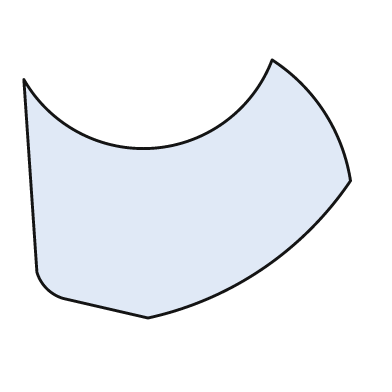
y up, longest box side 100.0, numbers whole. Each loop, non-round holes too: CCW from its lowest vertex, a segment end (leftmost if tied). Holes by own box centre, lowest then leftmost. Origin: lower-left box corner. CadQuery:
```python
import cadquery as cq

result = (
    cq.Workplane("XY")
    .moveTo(38.0, 0.0)
    .threePointArc((73.0, 15.0), (100.0, 42.0))
    .threePointArc((92.0, 63.0), (76.0, 79.0))
    .threePointArc((40.0, 52.0), (0.0, 73.0))
    .lineTo(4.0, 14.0)
    .threePointArc((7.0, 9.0), (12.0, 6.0))
    .close()
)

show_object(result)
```